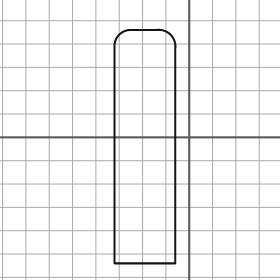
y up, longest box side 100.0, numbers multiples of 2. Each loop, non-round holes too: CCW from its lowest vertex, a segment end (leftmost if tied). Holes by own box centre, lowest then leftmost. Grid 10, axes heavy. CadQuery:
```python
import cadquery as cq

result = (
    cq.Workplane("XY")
    .moveTo(-32.0, -54.0)
    .lineTo(-6.0, -54.0)
    .lineTo(-6.0, 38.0)
    .threePointArc((-8.0, 44.0), (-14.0, 46.0))
    .lineTo(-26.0, 46.0)
    .threePointArc((-30.0, 44.0), (-32.0, 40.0))
    .close()
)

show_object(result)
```